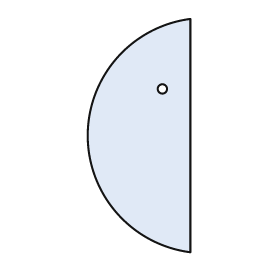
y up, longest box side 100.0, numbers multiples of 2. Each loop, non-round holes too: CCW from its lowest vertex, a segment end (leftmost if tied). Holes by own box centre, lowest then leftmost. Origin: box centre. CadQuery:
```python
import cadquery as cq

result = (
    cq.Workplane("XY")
    .moveTo(22.0, -50.0)
    .lineTo(22.0, 50.0)
    .threePointArc((-22.0, 0.0), (22.0, -50.0))
    .close()
    .moveTo(10.0, 20.0)
    .circle(2.0)
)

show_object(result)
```